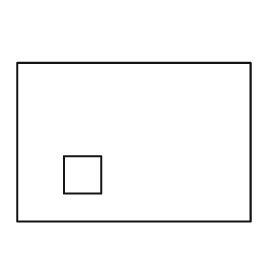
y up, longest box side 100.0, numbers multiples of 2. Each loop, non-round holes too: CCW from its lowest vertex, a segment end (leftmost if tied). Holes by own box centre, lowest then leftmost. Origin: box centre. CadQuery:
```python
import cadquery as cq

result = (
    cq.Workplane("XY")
    .moveTo(-50.0, -34.0)
    .lineTo(50.0, -34.0)
    .lineTo(50.0, 34.0)
    .lineTo(-50.0, 34.0)
    .close()
    .moveTo(-30.0, -22.0)
    .lineTo(-14.0, -22.0)
    .lineTo(-14.0, -6.0)
    .lineTo(-30.0, -6.0)
    .close()
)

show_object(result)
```